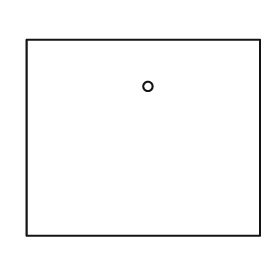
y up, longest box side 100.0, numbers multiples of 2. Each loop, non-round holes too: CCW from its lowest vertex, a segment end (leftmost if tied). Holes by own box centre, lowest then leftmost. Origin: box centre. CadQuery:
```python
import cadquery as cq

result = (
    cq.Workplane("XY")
    .moveTo(-50.0, -42.0)
    .lineTo(50.0, -42.0)
    .lineTo(50.0, 42.0)
    .lineTo(-50.0, 42.0)
    .close()
    .moveTo(2.0, 22.0)
    .circle(2.0)
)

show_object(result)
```